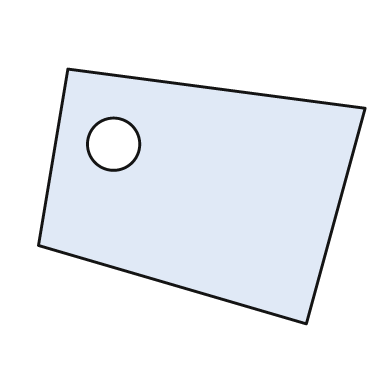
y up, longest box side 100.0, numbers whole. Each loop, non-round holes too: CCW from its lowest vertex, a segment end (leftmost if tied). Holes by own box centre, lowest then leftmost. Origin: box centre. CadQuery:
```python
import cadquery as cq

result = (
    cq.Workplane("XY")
    .moveTo(32.0, -39.0)
    .lineTo(50.0, 27.0)
    .lineTo(-41.0, 39.0)
    .lineTo(-50.0, -15.0)
    .close()
    .moveTo(-27.0, 16.0)
    .circle(8.0)
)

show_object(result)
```